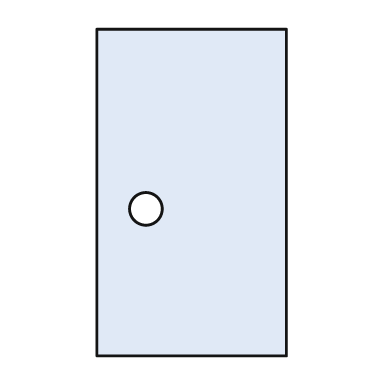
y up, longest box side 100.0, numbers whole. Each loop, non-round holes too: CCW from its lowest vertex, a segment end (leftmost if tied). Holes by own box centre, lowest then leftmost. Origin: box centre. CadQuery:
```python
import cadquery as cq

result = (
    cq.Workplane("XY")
    .moveTo(-29.0, -50.0)
    .lineTo(29.0, -50.0)
    .lineTo(29.0, 50.0)
    .lineTo(-29.0, 50.0)
    .close()
    .moveTo(-14.0, -5.0)
    .circle(5.0)
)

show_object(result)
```